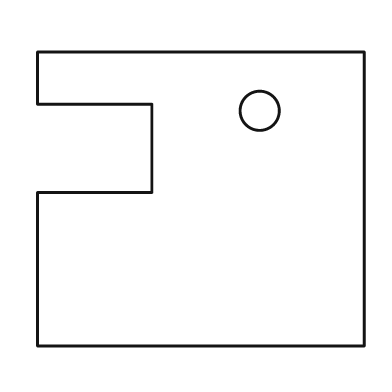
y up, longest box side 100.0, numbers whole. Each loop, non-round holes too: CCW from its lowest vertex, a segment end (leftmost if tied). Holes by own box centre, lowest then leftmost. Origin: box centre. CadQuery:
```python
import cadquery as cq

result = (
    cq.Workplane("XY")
    .moveTo(-50.0, -45.0)
    .lineTo(50.0, -45.0)
    .lineTo(50.0, 45.0)
    .lineTo(-50.0, 45.0)
    .lineTo(-50.0, 29.0)
    .lineTo(-15.0, 29.0)
    .lineTo(-15.0, 2.0)
    .lineTo(-50.0, 2.0)
    .close()
    .moveTo(18.0, 27.0)
    .circle(6.0)
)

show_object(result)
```